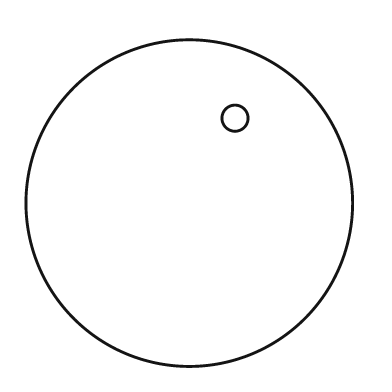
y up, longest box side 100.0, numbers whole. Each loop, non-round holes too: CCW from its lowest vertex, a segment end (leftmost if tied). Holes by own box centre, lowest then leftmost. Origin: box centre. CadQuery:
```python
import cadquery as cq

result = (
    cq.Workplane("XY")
    .moveTo(0.0, 0.0)
    .circle(50.0)
    .moveTo(14.0, 26.0)
    .circle(4.0)
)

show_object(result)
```